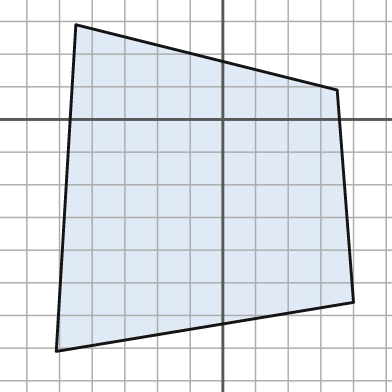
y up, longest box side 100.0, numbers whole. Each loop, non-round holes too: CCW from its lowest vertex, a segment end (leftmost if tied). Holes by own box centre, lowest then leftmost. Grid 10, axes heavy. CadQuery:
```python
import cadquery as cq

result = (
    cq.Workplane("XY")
    .moveTo(-51.0, -71.0)
    .lineTo(40.0, -56.0)
    .lineTo(35.0, 9.0)
    .lineTo(-45.0, 29.0)
    .close()
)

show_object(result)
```